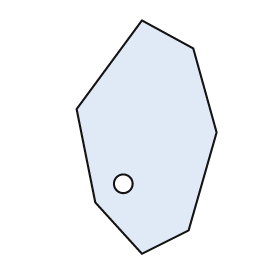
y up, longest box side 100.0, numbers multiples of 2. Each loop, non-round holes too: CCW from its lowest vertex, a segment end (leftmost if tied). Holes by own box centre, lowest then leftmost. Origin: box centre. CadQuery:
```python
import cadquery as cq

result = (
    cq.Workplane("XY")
    .moveTo(-2.0, -50.0)
    .lineTo(18.0, -40.0)
    .lineTo(30.0, 2.0)
    .lineTo(20.0, 38.0)
    .lineTo(-2.0, 50.0)
    .lineTo(-30.0, 12.0)
    .lineTo(-22.0, -28.0)
    .close()
    .moveTo(-10.0, -20.0)
    .circle(4.0)
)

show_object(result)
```